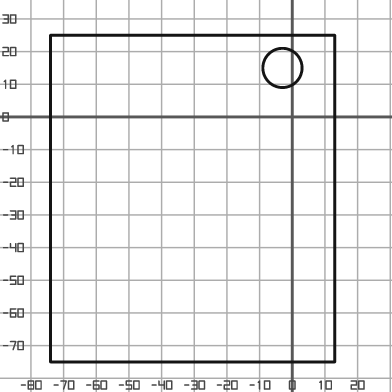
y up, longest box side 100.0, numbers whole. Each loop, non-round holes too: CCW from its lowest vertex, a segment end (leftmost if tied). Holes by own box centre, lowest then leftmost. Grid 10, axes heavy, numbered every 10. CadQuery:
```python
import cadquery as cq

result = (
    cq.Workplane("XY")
    .moveTo(-74.0, -75.0)
    .lineTo(13.0, -75.0)
    .lineTo(13.0, 25.0)
    .lineTo(-74.0, 25.0)
    .close()
    .moveTo(-3.0, 15.0)
    .circle(6.0)
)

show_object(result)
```